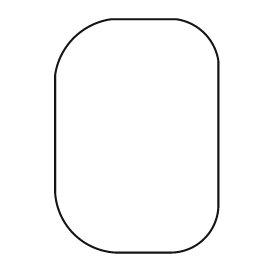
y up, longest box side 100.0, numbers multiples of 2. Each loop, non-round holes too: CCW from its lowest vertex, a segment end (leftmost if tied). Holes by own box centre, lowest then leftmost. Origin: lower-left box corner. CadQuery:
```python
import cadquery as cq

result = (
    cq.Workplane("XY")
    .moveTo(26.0, 0.0)
    .lineTo(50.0, 0.0)
    .threePointArc((64.0, 6.0), (70.0, 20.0))
    .lineTo(70.0, 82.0)
    .threePointArc((64.0, 94.0), (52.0, 100.0))
    .lineTo(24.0, 100.0)
    .threePointArc((8.0, 92.0), (0.0, 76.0))
    .lineTo(0.0, 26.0)
    .threePointArc((8.0, 8.0), (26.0, 0.0))
    .close()
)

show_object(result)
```